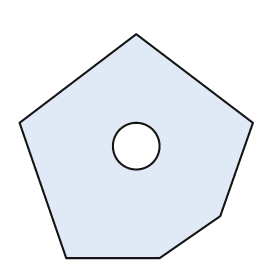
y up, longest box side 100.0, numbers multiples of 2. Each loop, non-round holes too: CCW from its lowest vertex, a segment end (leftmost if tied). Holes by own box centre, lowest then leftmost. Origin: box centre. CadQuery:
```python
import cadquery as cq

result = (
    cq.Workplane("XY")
    .moveTo(-30.0, -48.0)
    .lineTo(10.0, -48.0)
    .lineTo(36.0, -30.0)
    .lineTo(50.0, 10.0)
    .lineTo(0.0, 48.0)
    .lineTo(-50.0, 10.0)
    .close()
    .moveTo(0.0, 0.0)
    .circle(10.0)
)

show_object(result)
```